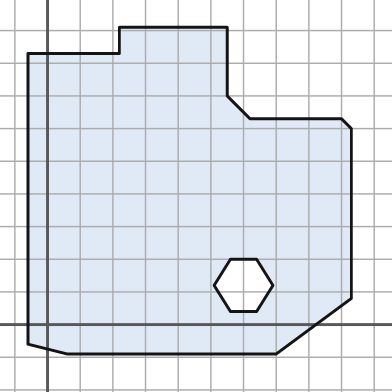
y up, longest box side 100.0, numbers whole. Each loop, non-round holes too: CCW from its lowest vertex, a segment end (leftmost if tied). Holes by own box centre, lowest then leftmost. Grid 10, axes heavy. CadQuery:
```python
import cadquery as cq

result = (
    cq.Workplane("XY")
    .moveTo(6.0, -9.0)
    .lineTo(70.0, -9.0)
    .lineTo(93.0, 8.0)
    .lineTo(93.0, 60.0)
    .lineTo(90.0, 63.0)
    .lineTo(62.0, 63.0)
    .lineTo(55.0, 70.0)
    .lineTo(55.0, 91.0)
    .lineTo(22.0, 91.0)
    .lineTo(22.0, 83.0)
    .lineTo(-6.0, 83.0)
    .lineTo(-6.0, -6.0)
    .close()
    .moveTo(56.0, 4.0)
    .lineTo(64.0, 4.0)
    .lineTo(69.0, 12.0)
    .lineTo(64.0, 20.0)
    .lineTo(56.0, 20.0)
    .lineTo(51.0, 12.0)
    .close()
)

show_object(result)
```